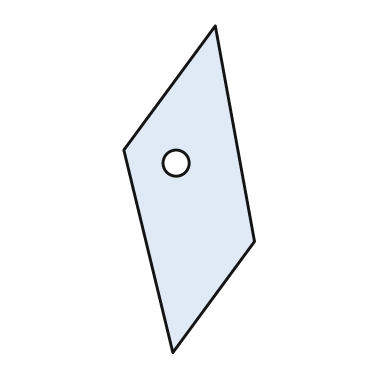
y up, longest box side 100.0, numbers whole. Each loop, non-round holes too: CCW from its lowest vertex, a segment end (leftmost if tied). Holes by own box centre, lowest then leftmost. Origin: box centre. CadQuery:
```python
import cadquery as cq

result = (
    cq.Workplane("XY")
    .moveTo(-5.0, -50.0)
    .lineTo(20.0, -16.0)
    .lineTo(8.0, 50.0)
    .lineTo(-20.0, 12.0)
    .close()
    .moveTo(-4.0, 8.0)
    .circle(4.0)
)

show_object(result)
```